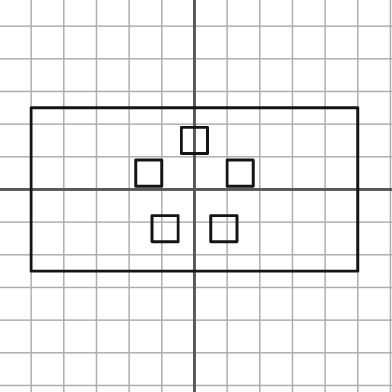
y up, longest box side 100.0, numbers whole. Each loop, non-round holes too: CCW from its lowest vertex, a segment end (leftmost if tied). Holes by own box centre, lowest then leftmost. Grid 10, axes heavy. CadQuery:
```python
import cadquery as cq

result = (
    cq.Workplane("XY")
    .moveTo(-50.0, -25.0)
    .lineTo(50.0, -25.0)
    .lineTo(50.0, 25.0)
    .lineTo(-50.0, 25.0)
    .close()
    .moveTo(-13.0, -16.0)
    .lineTo(-5.0, -16.0)
    .lineTo(-5.0, -8.0)
    .lineTo(-13.0, -8.0)
    .close()
    .moveTo(5.0, -16.0)
    .lineTo(13.0, -16.0)
    .lineTo(13.0, -8.0)
    .lineTo(5.0, -8.0)
    .close()
    .moveTo(-18.0, 1.0)
    .lineTo(-10.0, 1.0)
    .lineTo(-10.0, 9.0)
    .lineTo(-18.0, 9.0)
    .close()
    .moveTo(10.0, 1.0)
    .lineTo(18.0, 1.0)
    .lineTo(18.0, 9.0)
    .lineTo(10.0, 9.0)
    .close()
    .moveTo(-4.0, 11.0)
    .lineTo(4.0, 11.0)
    .lineTo(4.0, 19.0)
    .lineTo(-4.0, 19.0)
    .close()
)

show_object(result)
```